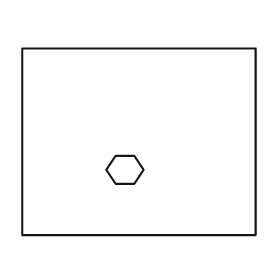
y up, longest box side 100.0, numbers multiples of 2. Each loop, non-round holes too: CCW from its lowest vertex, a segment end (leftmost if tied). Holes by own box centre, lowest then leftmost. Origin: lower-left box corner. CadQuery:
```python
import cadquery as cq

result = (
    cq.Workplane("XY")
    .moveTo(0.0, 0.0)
    .lineTo(100.0, 0.0)
    .lineTo(100.0, 80.0)
    .lineTo(0.0, 80.0)
    .close()
    .moveTo(40.0, 22.0)
    .lineTo(48.0, 22.0)
    .lineTo(52.0, 28.0)
    .lineTo(48.0, 34.0)
    .lineTo(40.0, 34.0)
    .lineTo(36.0, 28.0)
    .close()
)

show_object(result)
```